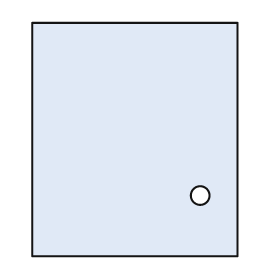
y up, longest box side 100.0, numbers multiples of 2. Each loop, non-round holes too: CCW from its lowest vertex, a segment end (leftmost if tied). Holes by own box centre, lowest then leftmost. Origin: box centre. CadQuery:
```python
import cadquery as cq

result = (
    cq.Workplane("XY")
    .moveTo(-44.0, -50.0)
    .lineTo(44.0, -50.0)
    .lineTo(44.0, 50.0)
    .lineTo(-44.0, 50.0)
    .close()
    .moveTo(28.0, -24.0)
    .circle(4.0)
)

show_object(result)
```